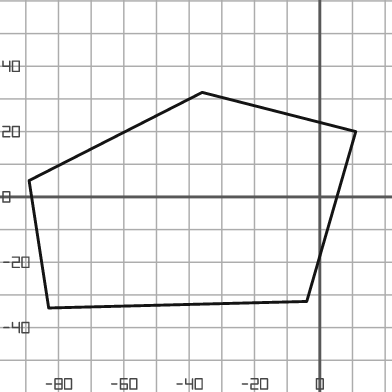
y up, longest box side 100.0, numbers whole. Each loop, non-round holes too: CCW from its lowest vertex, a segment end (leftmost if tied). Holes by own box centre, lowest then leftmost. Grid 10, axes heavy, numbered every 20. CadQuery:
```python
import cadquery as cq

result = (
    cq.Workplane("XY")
    .moveTo(-83.0, -34.0)
    .lineTo(-4.0, -32.0)
    .lineTo(11.0, 20.0)
    .lineTo(-36.0, 32.0)
    .lineTo(-89.0, 5.0)
    .close()
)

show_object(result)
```